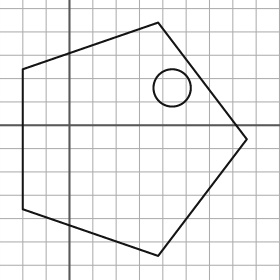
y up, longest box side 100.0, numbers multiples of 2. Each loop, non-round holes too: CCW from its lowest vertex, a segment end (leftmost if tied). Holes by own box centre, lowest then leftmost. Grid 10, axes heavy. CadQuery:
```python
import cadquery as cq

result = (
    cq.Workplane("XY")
    .moveTo(38.0, -56.0)
    .lineTo(76.0, -6.0)
    .lineTo(38.0, 44.0)
    .lineTo(-20.0, 24.0)
    .lineTo(-20.0, -36.0)
    .close()
    .moveTo(44.0, 16.0)
    .circle(8.0)
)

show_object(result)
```